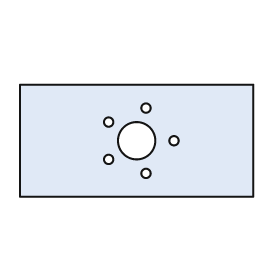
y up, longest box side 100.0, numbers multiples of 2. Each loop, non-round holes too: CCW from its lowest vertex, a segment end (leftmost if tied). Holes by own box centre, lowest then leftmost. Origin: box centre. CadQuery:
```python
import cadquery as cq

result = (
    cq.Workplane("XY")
    .moveTo(-50.0, -24.0)
    .lineTo(50.0, -24.0)
    .lineTo(50.0, 24.0)
    .lineTo(-50.0, 24.0)
    .close()
    .moveTo(4.0, -14.0)
    .circle(2.0)
    .moveTo(-12.0, -8.0)
    .circle(2.0)
    .moveTo(0.0, 0.0)
    .circle(8.0)
    .moveTo(16.0, 0.0)
    .circle(2.0)
    .moveTo(-12.0, 8.0)
    .circle(2.0)
    .moveTo(4.0, 14.0)
    .circle(2.0)
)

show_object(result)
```